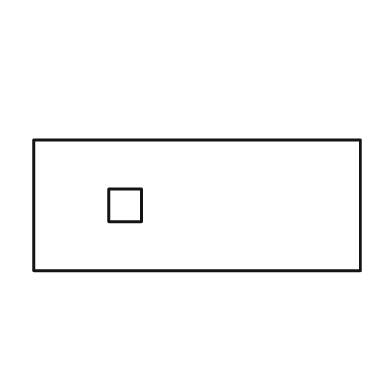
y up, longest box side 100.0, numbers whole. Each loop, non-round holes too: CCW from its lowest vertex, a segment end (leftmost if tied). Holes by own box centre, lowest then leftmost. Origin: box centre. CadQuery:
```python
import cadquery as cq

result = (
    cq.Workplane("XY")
    .moveTo(-50.0, -20.0)
    .lineTo(50.0, -20.0)
    .lineTo(50.0, 20.0)
    .lineTo(-50.0, 20.0)
    .close()
    .moveTo(-27.0, -5.0)
    .lineTo(-17.0, -5.0)
    .lineTo(-17.0, 5.0)
    .lineTo(-27.0, 5.0)
    .close()
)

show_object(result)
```